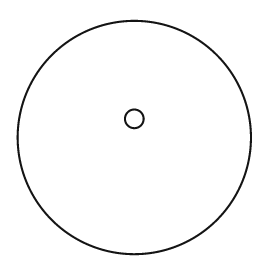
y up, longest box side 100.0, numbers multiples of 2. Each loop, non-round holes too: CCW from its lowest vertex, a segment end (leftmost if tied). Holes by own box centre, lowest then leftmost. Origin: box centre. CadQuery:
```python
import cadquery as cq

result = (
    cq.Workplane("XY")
    .moveTo(0.0, 0.0)
    .circle(50.0)
    .moveTo(0.0, 8.0)
    .circle(4.0)
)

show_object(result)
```